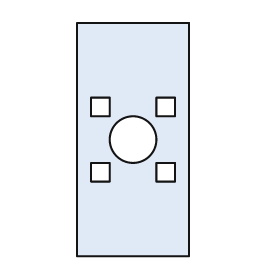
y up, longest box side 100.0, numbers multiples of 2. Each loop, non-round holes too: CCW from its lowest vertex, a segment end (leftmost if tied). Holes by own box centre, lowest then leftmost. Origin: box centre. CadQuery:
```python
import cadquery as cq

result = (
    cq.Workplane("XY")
    .moveTo(-24.0, -50.0)
    .lineTo(24.0, -50.0)
    .lineTo(24.0, 50.0)
    .lineTo(-24.0, 50.0)
    .close()
    .moveTo(-18.0, -18.0)
    .lineTo(-10.0, -18.0)
    .lineTo(-10.0, -10.0)
    .lineTo(-18.0, -10.0)
    .close()
    .moveTo(10.0, -18.0)
    .lineTo(18.0, -18.0)
    .lineTo(18.0, -10.0)
    .lineTo(10.0, -10.0)
    .close()
    .moveTo(0.0, 0.0)
    .circle(10.0)
    .moveTo(-18.0, 10.0)
    .lineTo(-10.0, 10.0)
    .lineTo(-10.0, 18.0)
    .lineTo(-18.0, 18.0)
    .close()
    .moveTo(10.0, 10.0)
    .lineTo(18.0, 10.0)
    .lineTo(18.0, 18.0)
    .lineTo(10.0, 18.0)
    .close()
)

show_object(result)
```